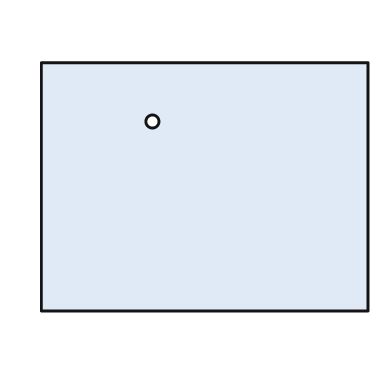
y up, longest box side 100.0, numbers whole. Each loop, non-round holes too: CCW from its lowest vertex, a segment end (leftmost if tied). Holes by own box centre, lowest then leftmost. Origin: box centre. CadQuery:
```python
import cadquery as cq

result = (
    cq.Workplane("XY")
    .moveTo(-50.0, -38.0)
    .lineTo(50.0, -38.0)
    .lineTo(50.0, 38.0)
    .lineTo(-50.0, 38.0)
    .close()
    .moveTo(-16.0, 20.0)
    .circle(2.0)
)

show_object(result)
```